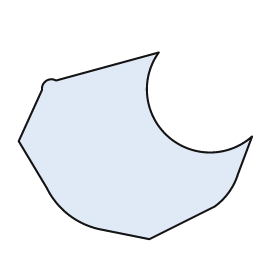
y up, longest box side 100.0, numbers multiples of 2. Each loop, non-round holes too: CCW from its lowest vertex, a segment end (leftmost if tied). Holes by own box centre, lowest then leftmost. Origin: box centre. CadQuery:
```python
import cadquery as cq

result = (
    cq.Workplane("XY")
    .moveTo(6.0, -40.0)
    .lineTo(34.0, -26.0)
    .threePointArc((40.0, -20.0), (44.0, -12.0))
    .lineTo(50.0, 4.0)
    .threePointArc((14.0, 4.0), (10.0, 40.0))
    .lineTo(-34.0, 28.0)
    .threePointArc((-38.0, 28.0), (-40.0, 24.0))
    .lineTo(-50.0, 2.0)
    .lineTo(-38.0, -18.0)
    .threePointArc((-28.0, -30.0), (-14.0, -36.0))
    .close()
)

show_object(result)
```